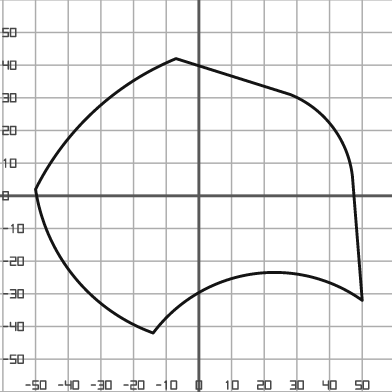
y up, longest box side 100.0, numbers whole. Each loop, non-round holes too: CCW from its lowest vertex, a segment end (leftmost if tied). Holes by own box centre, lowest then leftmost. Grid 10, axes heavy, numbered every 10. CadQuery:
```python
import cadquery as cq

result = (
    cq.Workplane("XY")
    .moveTo(-14.0, -42.0)
    .threePointArc((16.0, -24.0), (50.0, -32.0))
    .lineTo(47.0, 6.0)
    .threePointArc((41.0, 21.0), (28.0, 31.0))
    .lineTo(-7.0, 42.0)
    .threePointArc((-32.0, 26.0), (-50.0, 2.0))
    .threePointArc((-38.0, -25.0), (-14.0, -42.0))
    .close()
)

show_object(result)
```